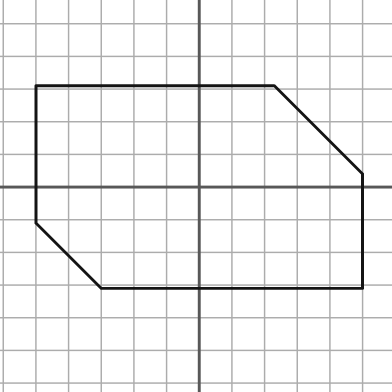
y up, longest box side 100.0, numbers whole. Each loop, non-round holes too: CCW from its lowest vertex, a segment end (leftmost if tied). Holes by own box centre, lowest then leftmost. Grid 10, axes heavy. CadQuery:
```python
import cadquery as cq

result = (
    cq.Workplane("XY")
    .moveTo(-30.0, -31.0)
    .lineTo(50.0, -31.0)
    .lineTo(50.0, 4.0)
    .lineTo(23.0, 31.0)
    .lineTo(-50.0, 31.0)
    .lineTo(-50.0, -11.0)
    .close()
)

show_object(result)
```